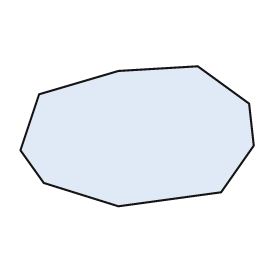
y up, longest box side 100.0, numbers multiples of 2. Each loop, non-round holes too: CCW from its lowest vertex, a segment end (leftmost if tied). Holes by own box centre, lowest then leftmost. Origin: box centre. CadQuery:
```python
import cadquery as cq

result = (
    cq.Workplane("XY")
    .moveTo(-8.0, -30.0)
    .lineTo(36.0, -24.0)
    .lineTo(50.0, -4.0)
    .lineTo(48.0, 14.0)
    .lineTo(26.0, 30.0)
    .lineTo(-8.0, 28.0)
    .lineTo(-42.0, 18.0)
    .lineTo(-50.0, -6.0)
    .lineTo(-40.0, -20.0)
    .close()
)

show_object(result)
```